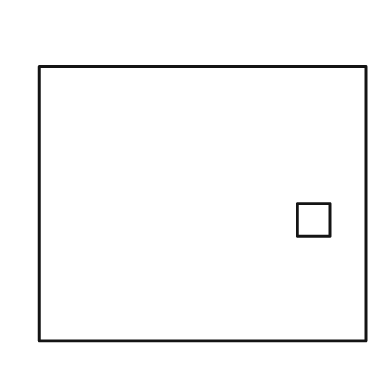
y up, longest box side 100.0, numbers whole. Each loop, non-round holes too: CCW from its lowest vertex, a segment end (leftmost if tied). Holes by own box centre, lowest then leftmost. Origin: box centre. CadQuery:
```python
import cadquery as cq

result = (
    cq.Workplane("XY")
    .moveTo(-50.0, -42.0)
    .lineTo(50.0, -42.0)
    .lineTo(50.0, 42.0)
    .lineTo(-50.0, 42.0)
    .close()
    .moveTo(29.0, -10.0)
    .lineTo(39.0, -10.0)
    .lineTo(39.0, 0.0)
    .lineTo(29.0, 0.0)
    .close()
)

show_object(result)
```